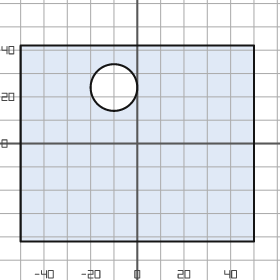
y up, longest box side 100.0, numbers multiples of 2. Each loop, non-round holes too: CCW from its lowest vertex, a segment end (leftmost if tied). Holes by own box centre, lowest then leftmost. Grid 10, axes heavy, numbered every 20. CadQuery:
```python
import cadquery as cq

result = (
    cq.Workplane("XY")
    .moveTo(-50.0, -42.0)
    .lineTo(50.0, -42.0)
    .lineTo(50.0, 42.0)
    .lineTo(-50.0, 42.0)
    .close()
    .moveTo(-10.0, 24.0)
    .circle(10.0)
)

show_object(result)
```